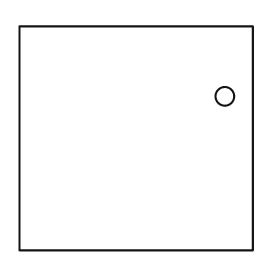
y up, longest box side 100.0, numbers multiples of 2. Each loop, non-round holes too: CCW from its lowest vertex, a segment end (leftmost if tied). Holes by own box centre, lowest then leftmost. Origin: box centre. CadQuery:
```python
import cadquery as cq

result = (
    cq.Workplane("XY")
    .moveTo(-50.0, -48.0)
    .lineTo(50.0, -48.0)
    .lineTo(50.0, 48.0)
    .lineTo(-50.0, 48.0)
    .close()
    .moveTo(38.0, 18.0)
    .circle(4.0)
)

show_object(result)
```